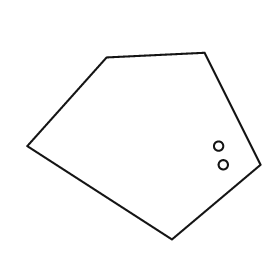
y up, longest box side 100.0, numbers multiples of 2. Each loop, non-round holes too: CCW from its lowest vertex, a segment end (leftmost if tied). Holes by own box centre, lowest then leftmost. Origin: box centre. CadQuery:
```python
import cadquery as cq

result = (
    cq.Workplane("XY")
    .moveTo(12.0, -40.0)
    .lineTo(50.0, -8.0)
    .lineTo(26.0, 40.0)
    .lineTo(-16.0, 38.0)
    .lineTo(-50.0, 0.0)
    .close()
    .moveTo(34.0, -8.0)
    .circle(2.0)
    .moveTo(32.0, 0.0)
    .circle(2.0)
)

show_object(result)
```